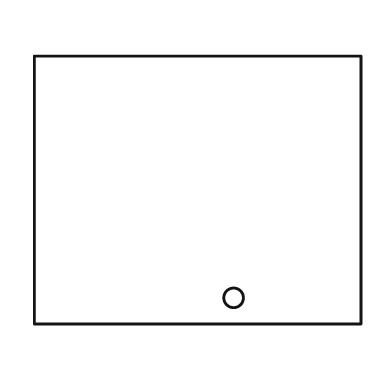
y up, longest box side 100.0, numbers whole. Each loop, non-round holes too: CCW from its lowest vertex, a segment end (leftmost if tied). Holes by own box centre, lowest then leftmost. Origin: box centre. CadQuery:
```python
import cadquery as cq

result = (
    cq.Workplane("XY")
    .moveTo(-50.0, -41.0)
    .lineTo(50.0, -41.0)
    .lineTo(50.0, 41.0)
    .lineTo(-50.0, 41.0)
    .close()
    .moveTo(11.0, -33.0)
    .circle(3.0)
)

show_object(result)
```